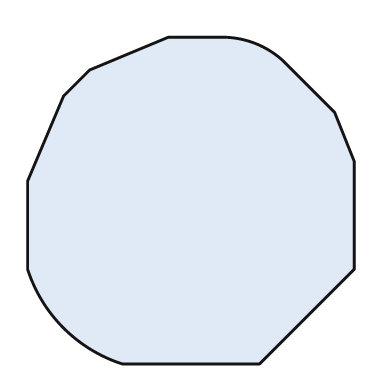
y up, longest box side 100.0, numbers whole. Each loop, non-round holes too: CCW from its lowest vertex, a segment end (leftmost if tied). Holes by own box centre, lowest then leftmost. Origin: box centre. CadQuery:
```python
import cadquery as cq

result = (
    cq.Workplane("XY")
    .moveTo(-21.0, -50.0)
    .lineTo(21.0, -50.0)
    .lineTo(50.0, -21.0)
    .lineTo(50.0, 12.0)
    .lineTo(44.0, 27.0)
    .lineTo(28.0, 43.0)
    .threePointArc((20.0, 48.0), (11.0, 50.0))
    .lineTo(-7.0, 50.0)
    .lineTo(-31.0, 40.0)
    .lineTo(-39.0, 32.0)
    .lineTo(-50.0, 6.0)
    .lineTo(-50.0, -21.0)
    .threePointArc((-39.0, -39.0), (-21.0, -50.0))
    .close()
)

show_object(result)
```